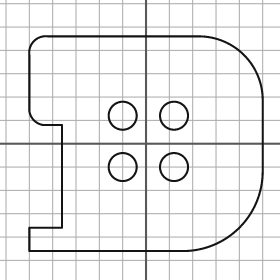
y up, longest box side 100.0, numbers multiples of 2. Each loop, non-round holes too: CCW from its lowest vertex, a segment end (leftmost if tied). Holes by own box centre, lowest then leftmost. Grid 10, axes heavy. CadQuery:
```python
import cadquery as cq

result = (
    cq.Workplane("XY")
    .moveTo(-50.0, -46.0)
    .lineTo(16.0, -46.0)
    .threePointArc((40.0, -36.0), (50.0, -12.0))
    .lineTo(50.0, 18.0)
    .threePointArc((42.0, 38.0), (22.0, 46.0))
    .lineTo(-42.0, 46.0)
    .threePointArc((-48.0, 44.0), (-50.0, 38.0))
    .lineTo(-50.0, 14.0)
    .threePointArc((-48.0, 10.0), (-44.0, 8.0))
    .lineTo(-36.0, 8.0)
    .lineTo(-36.0, -36.0)
    .lineTo(-50.0, -36.0)
    .close()
    .moveTo(-10.0, -10.0)
    .circle(6.0)
    .moveTo(12.0, -10.0)
    .circle(6.0)
    .moveTo(-10.0, 12.0)
    .circle(6.0)
    .moveTo(12.0, 12.0)
    .circle(6.0)
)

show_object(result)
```